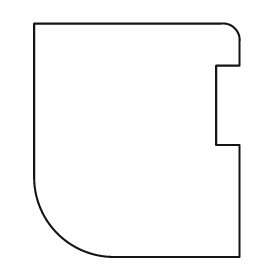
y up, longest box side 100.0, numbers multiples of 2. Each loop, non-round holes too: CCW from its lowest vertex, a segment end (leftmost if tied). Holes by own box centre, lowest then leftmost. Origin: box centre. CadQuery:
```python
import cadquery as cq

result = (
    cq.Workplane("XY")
    .moveTo(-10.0, -50.0)
    .lineTo(44.0, -50.0)
    .lineTo(44.0, -2.0)
    .lineTo(34.0, -2.0)
    .lineTo(34.0, 32.0)
    .lineTo(44.0, 32.0)
    .lineTo(44.0, 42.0)
    .threePointArc((42.0, 48.0), (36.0, 50.0))
    .lineTo(-44.0, 50.0)
    .lineTo(-44.0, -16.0)
    .threePointArc((-34.0, -40.0), (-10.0, -50.0))
    .close()
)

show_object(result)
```